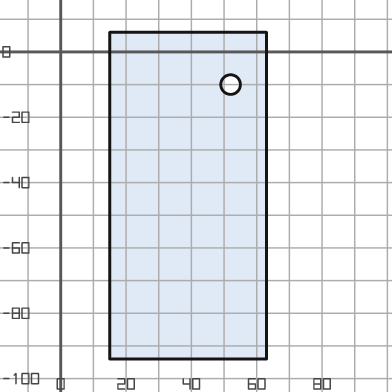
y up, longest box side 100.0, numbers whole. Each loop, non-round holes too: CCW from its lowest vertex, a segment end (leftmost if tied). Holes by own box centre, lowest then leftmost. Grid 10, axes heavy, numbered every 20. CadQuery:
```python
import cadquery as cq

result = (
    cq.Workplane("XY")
    .moveTo(15.0, -94.0)
    .lineTo(63.0, -94.0)
    .lineTo(63.0, 6.0)
    .lineTo(15.0, 6.0)
    .close()
    .moveTo(52.0, -10.0)
    .circle(3.0)
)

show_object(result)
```